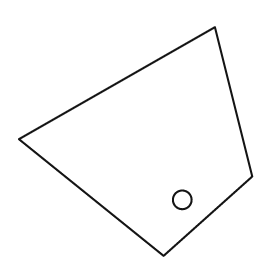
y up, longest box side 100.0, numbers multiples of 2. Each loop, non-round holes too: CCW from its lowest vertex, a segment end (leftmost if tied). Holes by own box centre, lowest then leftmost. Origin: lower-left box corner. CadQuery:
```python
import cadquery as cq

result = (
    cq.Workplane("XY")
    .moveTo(62.0, 0.0)
    .lineTo(100.0, 34.0)
    .lineTo(84.0, 98.0)
    .lineTo(0.0, 50.0)
    .close()
    .moveTo(70.0, 24.0)
    .circle(4.0)
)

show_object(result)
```